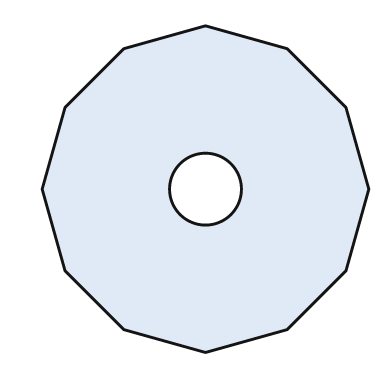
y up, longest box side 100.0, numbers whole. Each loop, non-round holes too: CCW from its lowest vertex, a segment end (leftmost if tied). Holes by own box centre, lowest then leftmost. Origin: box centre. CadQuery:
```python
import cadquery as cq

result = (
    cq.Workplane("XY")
    .moveTo(0.0, -50.0)
    .lineTo(25.0, -43.0)
    .lineTo(43.0, -25.0)
    .lineTo(50.0, 0.0)
    .lineTo(43.0, 25.0)
    .lineTo(25.0, 43.0)
    .lineTo(0.0, 50.0)
    .lineTo(-25.0, 43.0)
    .lineTo(-43.0, 25.0)
    .lineTo(-50.0, 0.0)
    .lineTo(-43.0, -25.0)
    .lineTo(-25.0, -43.0)
    .close()
    .moveTo(0.0, 0.0)
    .circle(11.0)
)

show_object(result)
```